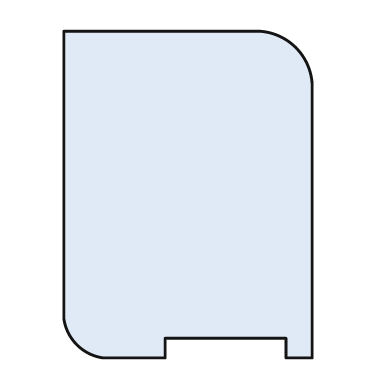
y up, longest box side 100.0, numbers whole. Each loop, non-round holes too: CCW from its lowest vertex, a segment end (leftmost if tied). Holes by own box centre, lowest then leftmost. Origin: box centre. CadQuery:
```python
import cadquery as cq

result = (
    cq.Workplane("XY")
    .moveTo(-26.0, -50.0)
    .lineTo(-7.0, -50.0)
    .lineTo(-7.0, -44.0)
    .lineTo(30.0, -44.0)
    .lineTo(30.0, -50.0)
    .lineTo(38.0, -50.0)
    .lineTo(38.0, 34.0)
    .threePointArc((33.0, 45.0), (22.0, 50.0))
    .lineTo(-38.0, 50.0)
    .lineTo(-38.0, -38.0)
    .threePointArc((-34.0, -46.0), (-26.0, -50.0))
    .close()
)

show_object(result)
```